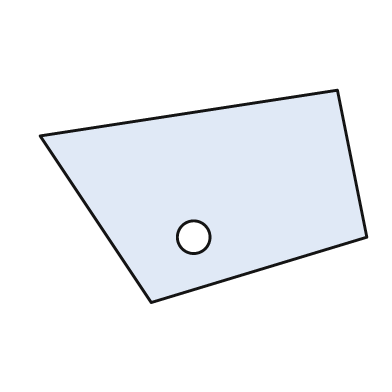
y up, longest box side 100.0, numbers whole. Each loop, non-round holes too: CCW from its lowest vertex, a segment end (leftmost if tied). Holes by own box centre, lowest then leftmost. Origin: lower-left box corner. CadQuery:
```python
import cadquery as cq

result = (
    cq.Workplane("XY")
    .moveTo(34.0, 0.0)
    .lineTo(100.0, 20.0)
    .lineTo(91.0, 65.0)
    .lineTo(0.0, 51.0)
    .close()
    .moveTo(47.0, 20.0)
    .circle(5.0)
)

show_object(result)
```